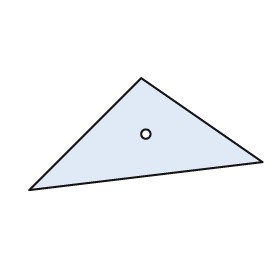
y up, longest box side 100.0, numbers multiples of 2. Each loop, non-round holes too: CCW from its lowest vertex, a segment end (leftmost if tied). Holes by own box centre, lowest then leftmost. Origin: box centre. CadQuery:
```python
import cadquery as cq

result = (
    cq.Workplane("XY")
    .moveTo(-50.0, -24.0)
    .lineTo(50.0, -12.0)
    .lineTo(-2.0, 24.0)
    .close()
    .moveTo(0.0, 0.0)
    .circle(2.0)
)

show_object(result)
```